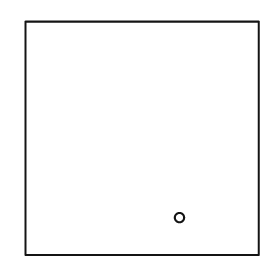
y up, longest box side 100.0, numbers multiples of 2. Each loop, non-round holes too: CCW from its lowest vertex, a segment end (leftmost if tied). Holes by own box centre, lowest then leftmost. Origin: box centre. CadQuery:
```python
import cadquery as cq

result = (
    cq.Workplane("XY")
    .moveTo(-50.0, -50.0)
    .lineTo(50.0, -50.0)
    .lineTo(50.0, 50.0)
    .lineTo(-50.0, 50.0)
    .close()
    .moveTo(16.0, -34.0)
    .circle(2.0)
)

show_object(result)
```